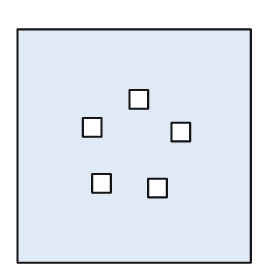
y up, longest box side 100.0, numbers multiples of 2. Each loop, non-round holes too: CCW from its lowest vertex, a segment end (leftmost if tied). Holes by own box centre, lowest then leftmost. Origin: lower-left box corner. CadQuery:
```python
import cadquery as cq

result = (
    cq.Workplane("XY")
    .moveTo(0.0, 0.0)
    .lineTo(100.0, 0.0)
    .lineTo(100.0, 100.0)
    .lineTo(0.0, 100.0)
    .close()
    .moveTo(56.0, 28.0)
    .lineTo(64.0, 28.0)
    .lineTo(64.0, 36.0)
    .lineTo(56.0, 36.0)
    .close()
    .moveTo(32.0, 30.0)
    .lineTo(40.0, 30.0)
    .lineTo(40.0, 38.0)
    .lineTo(32.0, 38.0)
    .close()
    .moveTo(66.0, 52.0)
    .lineTo(74.0, 52.0)
    .lineTo(74.0, 60.0)
    .lineTo(66.0, 60.0)
    .close()
    .moveTo(28.0, 54.0)
    .lineTo(36.0, 54.0)
    .lineTo(36.0, 62.0)
    .lineTo(28.0, 62.0)
    .close()
    .moveTo(48.0, 66.0)
    .lineTo(56.0, 66.0)
    .lineTo(56.0, 74.0)
    .lineTo(48.0, 74.0)
    .close()
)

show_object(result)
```